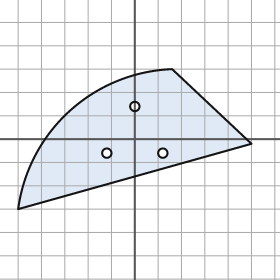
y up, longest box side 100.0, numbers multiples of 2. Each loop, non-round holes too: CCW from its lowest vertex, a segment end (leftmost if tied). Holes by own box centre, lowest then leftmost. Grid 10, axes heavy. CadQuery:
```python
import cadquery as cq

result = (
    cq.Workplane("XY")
    .moveTo(-50.0, -30.0)
    .lineTo(50.0, -2.0)
    .lineTo(16.0, 30.0)
    .threePointArc((-28.0, 12.0), (-50.0, -30.0))
    .close()
    .moveTo(-12.0, -6.0)
    .circle(2.0)
    .moveTo(12.0, -6.0)
    .circle(2.0)
    .moveTo(0.0, 14.0)
    .circle(2.0)
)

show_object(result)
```